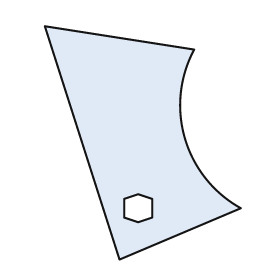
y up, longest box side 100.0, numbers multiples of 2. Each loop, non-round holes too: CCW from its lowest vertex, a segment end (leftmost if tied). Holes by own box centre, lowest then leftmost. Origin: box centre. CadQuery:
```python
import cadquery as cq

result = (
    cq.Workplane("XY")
    .moveTo(-10.0, -50.0)
    .lineTo(42.0, -28.0)
    .threePointArc((18.0, 2.0), (22.0, 40.0))
    .lineTo(-42.0, 50.0)
    .close()
    .moveTo(-2.0, -34.0)
    .lineTo(4.0, -32.0)
    .lineTo(4.0, -24.0)
    .lineTo(-2.0, -22.0)
    .lineTo(-8.0, -24.0)
    .lineTo(-8.0, -32.0)
    .close()
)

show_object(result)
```